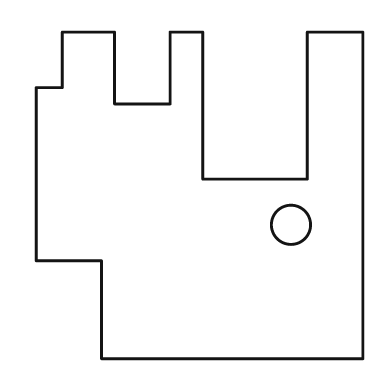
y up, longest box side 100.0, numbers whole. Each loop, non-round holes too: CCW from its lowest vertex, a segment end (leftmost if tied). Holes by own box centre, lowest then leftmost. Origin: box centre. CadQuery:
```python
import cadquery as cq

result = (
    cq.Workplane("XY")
    .moveTo(-30.0, -50.0)
    .lineTo(50.0, -50.0)
    .lineTo(50.0, 50.0)
    .lineTo(33.0, 50.0)
    .lineTo(33.0, 5.0)
    .lineTo(1.0, 5.0)
    .lineTo(1.0, 50.0)
    .lineTo(-9.0, 50.0)
    .lineTo(-9.0, 28.0)
    .lineTo(-26.0, 28.0)
    .lineTo(-26.0, 50.0)
    .lineTo(-42.0, 50.0)
    .lineTo(-42.0, 33.0)
    .lineTo(-50.0, 33.0)
    .lineTo(-50.0, -20.0)
    .lineTo(-30.0, -20.0)
    .close()
    .moveTo(28.0, -9.0)
    .circle(6.0)
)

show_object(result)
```